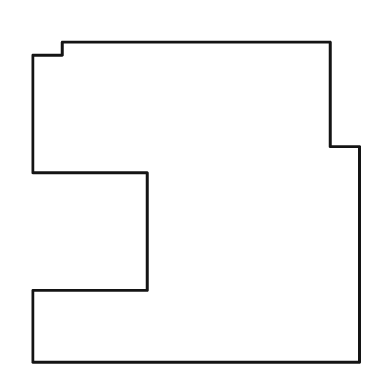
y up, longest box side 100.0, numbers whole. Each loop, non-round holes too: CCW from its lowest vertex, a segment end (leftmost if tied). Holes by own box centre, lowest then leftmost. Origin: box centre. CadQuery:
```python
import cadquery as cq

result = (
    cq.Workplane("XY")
    .moveTo(-50.0, -49.0)
    .lineTo(50.0, -49.0)
    .lineTo(50.0, 17.0)
    .lineTo(41.0, 17.0)
    .lineTo(41.0, 49.0)
    .lineTo(-41.0, 49.0)
    .lineTo(-41.0, 45.0)
    .lineTo(-50.0, 45.0)
    .lineTo(-50.0, 9.0)
    .lineTo(-15.0, 9.0)
    .lineTo(-15.0, -27.0)
    .lineTo(-50.0, -27.0)
    .close()
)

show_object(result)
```